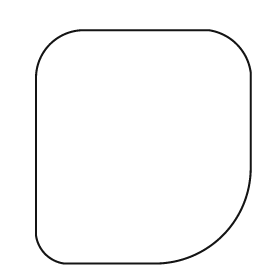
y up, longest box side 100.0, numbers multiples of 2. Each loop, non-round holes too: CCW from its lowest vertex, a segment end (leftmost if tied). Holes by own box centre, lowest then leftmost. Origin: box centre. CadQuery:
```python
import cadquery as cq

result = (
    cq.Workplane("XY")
    .moveTo(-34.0, -50.0)
    .lineTo(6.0, -50.0)
    .threePointArc((34.0, -38.0), (46.0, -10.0))
    .lineTo(46.0, 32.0)
    .threePointArc((40.0, 44.0), (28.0, 50.0))
    .lineTo(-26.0, 50.0)
    .threePointArc((-40.0, 44.0), (-46.0, 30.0))
    .lineTo(-46.0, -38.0)
    .threePointArc((-42.0, -46.0), (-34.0, -50.0))
    .close()
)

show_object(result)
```